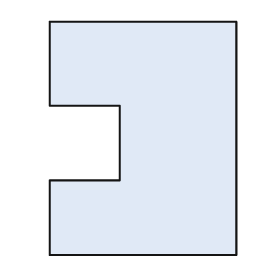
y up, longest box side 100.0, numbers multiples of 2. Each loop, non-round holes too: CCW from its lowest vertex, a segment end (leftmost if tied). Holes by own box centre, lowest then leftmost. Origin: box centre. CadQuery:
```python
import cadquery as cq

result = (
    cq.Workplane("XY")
    .moveTo(-40.0, -50.0)
    .lineTo(40.0, -50.0)
    .lineTo(40.0, 50.0)
    .lineTo(-40.0, 50.0)
    .lineTo(-40.0, 14.0)
    .lineTo(-10.0, 14.0)
    .lineTo(-10.0, -18.0)
    .lineTo(-40.0, -18.0)
    .close()
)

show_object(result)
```